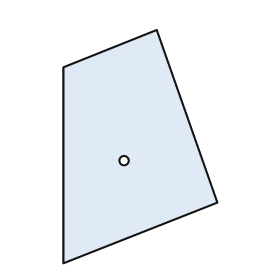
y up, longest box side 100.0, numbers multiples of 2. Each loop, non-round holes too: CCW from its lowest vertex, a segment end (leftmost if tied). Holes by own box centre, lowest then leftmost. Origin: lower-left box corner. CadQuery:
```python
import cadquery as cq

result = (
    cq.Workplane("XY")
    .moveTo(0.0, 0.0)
    .lineTo(66.0, 26.0)
    .lineTo(40.0, 100.0)
    .lineTo(0.0, 84.0)
    .close()
    .moveTo(26.0, 44.0)
    .circle(2.0)
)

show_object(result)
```